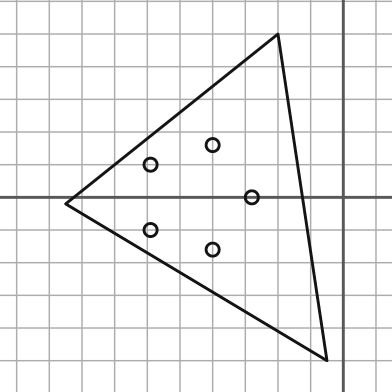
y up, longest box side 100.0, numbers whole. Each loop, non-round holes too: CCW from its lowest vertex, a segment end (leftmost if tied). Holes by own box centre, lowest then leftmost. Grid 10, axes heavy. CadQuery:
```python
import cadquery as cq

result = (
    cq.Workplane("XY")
    .moveTo(-5.0, -50.0)
    .lineTo(-20.0, 50.0)
    .lineTo(-85.0, -2.0)
    .close()
    .moveTo(-40.0, -16.0)
    .circle(2.0)
    .moveTo(-59.0, -10.0)
    .circle(2.0)
    .moveTo(-28.0, 0.0)
    .circle(2.0)
    .moveTo(-59.0, 10.0)
    .circle(2.0)
    .moveTo(-40.0, 16.0)
    .circle(2.0)
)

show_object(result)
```